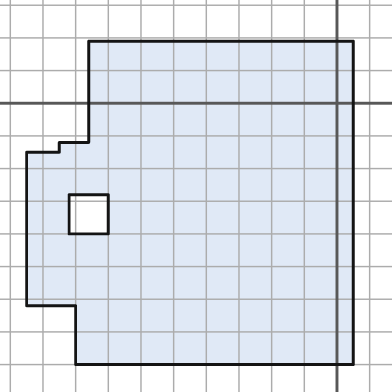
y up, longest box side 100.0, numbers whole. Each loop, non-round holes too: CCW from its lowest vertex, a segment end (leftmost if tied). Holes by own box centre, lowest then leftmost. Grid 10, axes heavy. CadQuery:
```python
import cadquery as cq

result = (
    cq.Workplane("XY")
    .moveTo(-80.0, -80.0)
    .lineTo(5.0, -80.0)
    .lineTo(5.0, 19.0)
    .lineTo(-76.0, 19.0)
    .lineTo(-76.0, -12.0)
    .lineTo(-85.0, -12.0)
    .lineTo(-85.0, -15.0)
    .lineTo(-95.0, -15.0)
    .lineTo(-95.0, -62.0)
    .lineTo(-80.0, -62.0)
    .close()
    .moveTo(-82.0, -40.0)
    .lineTo(-70.0, -40.0)
    .lineTo(-70.0, -28.0)
    .lineTo(-82.0, -28.0)
    .close()
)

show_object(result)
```